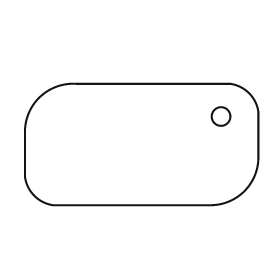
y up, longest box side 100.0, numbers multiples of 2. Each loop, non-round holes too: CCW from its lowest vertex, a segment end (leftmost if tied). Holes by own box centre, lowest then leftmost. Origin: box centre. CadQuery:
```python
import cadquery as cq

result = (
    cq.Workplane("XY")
    .moveTo(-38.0, -26.0)
    .lineTo(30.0, -26.0)
    .threePointArc((44.0, -20.0), (50.0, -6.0))
    .lineTo(50.0, 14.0)
    .threePointArc((46.0, 22.0), (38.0, 26.0))
    .lineTo(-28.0, 26.0)
    .threePointArc((-44.0, 20.0), (-50.0, 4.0))
    .lineTo(-50.0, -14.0)
    .threePointArc((-46.0, -22.0), (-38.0, -26.0))
    .close()
    .moveTo(34.0, 12.0)
    .circle(4.0)
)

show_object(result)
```